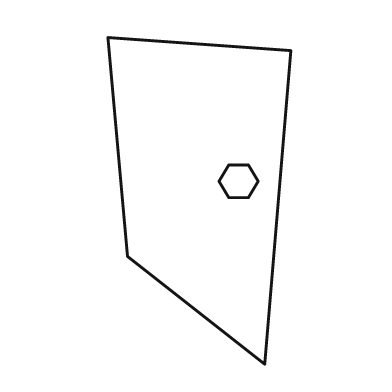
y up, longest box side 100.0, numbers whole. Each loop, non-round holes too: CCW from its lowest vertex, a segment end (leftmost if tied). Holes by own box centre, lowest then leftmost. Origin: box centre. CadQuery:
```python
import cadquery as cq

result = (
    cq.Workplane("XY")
    .moveTo(20.0, -50.0)
    .lineTo(28.0, 46.0)
    .lineTo(-28.0, 50.0)
    .lineTo(-22.0, -17.0)
    .close()
    .moveTo(9.0, 1.0)
    .lineTo(15.0, 1.0)
    .lineTo(18.0, 6.0)
    .lineTo(15.0, 11.0)
    .lineTo(9.0, 11.0)
    .lineTo(6.0, 6.0)
    .close()
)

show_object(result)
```